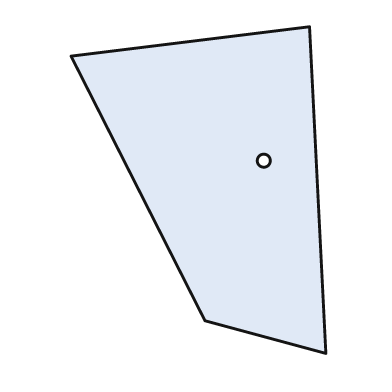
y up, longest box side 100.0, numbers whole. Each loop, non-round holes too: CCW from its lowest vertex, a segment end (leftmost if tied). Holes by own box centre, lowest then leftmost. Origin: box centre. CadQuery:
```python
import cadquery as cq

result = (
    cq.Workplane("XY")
    .moveTo(39.0, -50.0)
    .lineTo(34.0, 50.0)
    .lineTo(-39.0, 41.0)
    .lineTo(2.0, -40.0)
    .close()
    .moveTo(20.0, 9.0)
    .circle(2.0)
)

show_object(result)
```